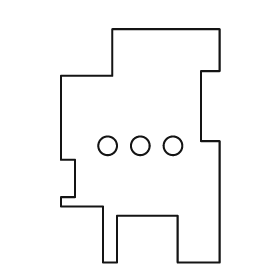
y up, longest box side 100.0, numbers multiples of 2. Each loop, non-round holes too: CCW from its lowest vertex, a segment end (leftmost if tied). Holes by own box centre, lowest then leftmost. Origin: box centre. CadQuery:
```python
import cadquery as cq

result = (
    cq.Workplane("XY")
    .moveTo(-16.0, -50.0)
    .lineTo(-10.0, -50.0)
    .lineTo(-10.0, -30.0)
    .lineTo(16.0, -30.0)
    .lineTo(16.0, -50.0)
    .lineTo(34.0, -50.0)
    .lineTo(34.0, 2.0)
    .lineTo(26.0, 2.0)
    .lineTo(26.0, 32.0)
    .lineTo(34.0, 32.0)
    .lineTo(34.0, 50.0)
    .lineTo(-12.0, 50.0)
    .lineTo(-12.0, 30.0)
    .lineTo(-34.0, 30.0)
    .lineTo(-34.0, -6.0)
    .lineTo(-28.0, -6.0)
    .lineTo(-28.0, -22.0)
    .lineTo(-34.0, -22.0)
    .lineTo(-34.0, -26.0)
    .lineTo(-16.0, -26.0)
    .close()
    .moveTo(-14.0, 0.0)
    .circle(4.0)
    .moveTo(0.0, 0.0)
    .circle(4.0)
    .moveTo(14.0, 0.0)
    .circle(4.0)
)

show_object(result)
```